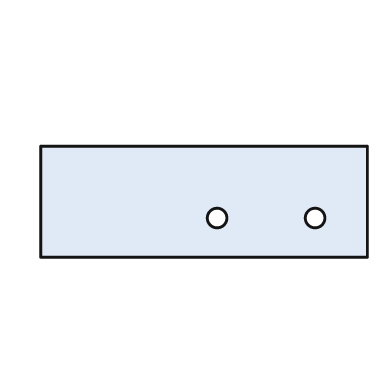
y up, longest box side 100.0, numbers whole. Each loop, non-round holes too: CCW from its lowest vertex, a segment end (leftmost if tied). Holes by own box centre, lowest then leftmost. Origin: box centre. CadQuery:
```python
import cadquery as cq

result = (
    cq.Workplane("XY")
    .moveTo(-50.0, -17.0)
    .lineTo(50.0, -17.0)
    .lineTo(50.0, 17.0)
    .lineTo(-50.0, 17.0)
    .close()
    .moveTo(4.0, -5.0)
    .circle(3.0)
    .moveTo(34.0, -5.0)
    .circle(3.0)
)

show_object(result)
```